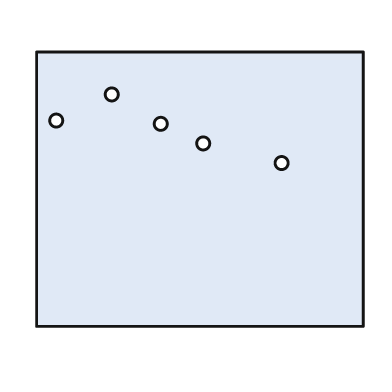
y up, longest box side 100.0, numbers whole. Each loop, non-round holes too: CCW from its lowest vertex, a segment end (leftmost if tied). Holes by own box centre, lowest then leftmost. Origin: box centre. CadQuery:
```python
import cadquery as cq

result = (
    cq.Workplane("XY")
    .moveTo(-50.0, -42.0)
    .lineTo(50.0, -42.0)
    .lineTo(50.0, 42.0)
    .lineTo(-50.0, 42.0)
    .close()
    .moveTo(25.0, 8.0)
    .circle(2.0)
    .moveTo(1.0, 14.0)
    .circle(2.0)
    .moveTo(-12.0, 20.0)
    .circle(2.0)
    .moveTo(-44.0, 21.0)
    .circle(2.0)
    .moveTo(-27.0, 29.0)
    .circle(2.0)
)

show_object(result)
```